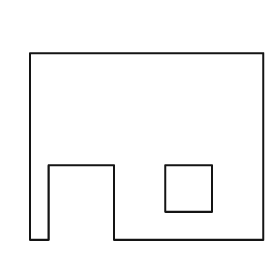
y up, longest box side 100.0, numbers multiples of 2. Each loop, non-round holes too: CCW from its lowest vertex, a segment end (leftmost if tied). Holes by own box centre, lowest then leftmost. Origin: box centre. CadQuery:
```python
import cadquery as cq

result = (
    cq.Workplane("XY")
    .moveTo(-50.0, -40.0)
    .lineTo(-42.0, -40.0)
    .lineTo(-42.0, -8.0)
    .lineTo(-14.0, -8.0)
    .lineTo(-14.0, -40.0)
    .lineTo(50.0, -40.0)
    .lineTo(50.0, 40.0)
    .lineTo(-50.0, 40.0)
    .close()
    .moveTo(8.0, -28.0)
    .lineTo(28.0, -28.0)
    .lineTo(28.0, -8.0)
    .lineTo(8.0, -8.0)
    .close()
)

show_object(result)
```